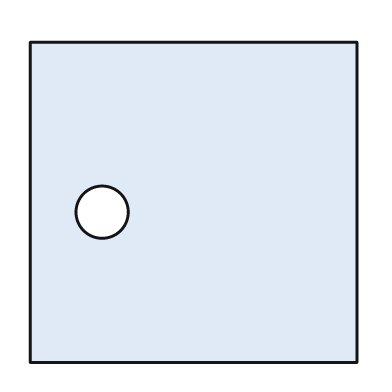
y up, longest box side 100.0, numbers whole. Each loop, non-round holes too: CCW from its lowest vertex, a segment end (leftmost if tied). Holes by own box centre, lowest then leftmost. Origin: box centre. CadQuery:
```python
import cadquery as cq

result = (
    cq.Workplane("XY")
    .moveTo(-50.0, -49.0)
    .lineTo(50.0, -49.0)
    .lineTo(50.0, 49.0)
    .lineTo(-50.0, 49.0)
    .close()
    .moveTo(-28.0, -3.0)
    .circle(8.0)
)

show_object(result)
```